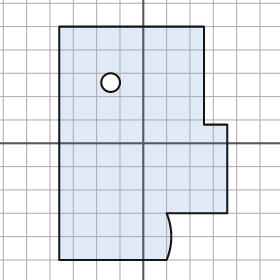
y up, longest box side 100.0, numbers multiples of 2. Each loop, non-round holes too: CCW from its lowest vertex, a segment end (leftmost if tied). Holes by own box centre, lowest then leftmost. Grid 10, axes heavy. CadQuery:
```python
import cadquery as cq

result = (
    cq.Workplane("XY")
    .moveTo(-36.0, -50.0)
    .lineTo(10.0, -50.0)
    .threePointArc((12.0, -40.0), (10.0, -30.0))
    .lineTo(36.0, -30.0)
    .lineTo(36.0, 8.0)
    .lineTo(26.0, 8.0)
    .lineTo(26.0, 50.0)
    .lineTo(-36.0, 50.0)
    .close()
    .moveTo(-14.0, 26.0)
    .circle(4.0)
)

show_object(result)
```